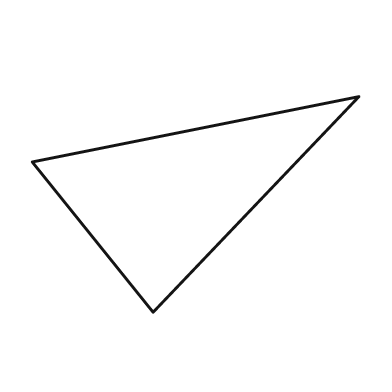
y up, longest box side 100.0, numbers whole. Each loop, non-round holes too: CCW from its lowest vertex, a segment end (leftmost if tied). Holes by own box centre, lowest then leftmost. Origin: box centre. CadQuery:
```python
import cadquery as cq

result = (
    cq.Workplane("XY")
    .moveTo(-13.0, -33.0)
    .lineTo(50.0, 33.0)
    .lineTo(-50.0, 13.0)
    .close()
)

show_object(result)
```